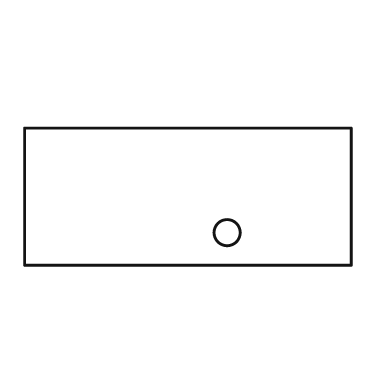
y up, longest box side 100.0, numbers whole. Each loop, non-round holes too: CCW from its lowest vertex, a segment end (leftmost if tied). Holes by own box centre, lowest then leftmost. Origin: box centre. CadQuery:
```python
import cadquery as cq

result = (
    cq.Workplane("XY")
    .moveTo(-50.0, -21.0)
    .lineTo(50.0, -21.0)
    .lineTo(50.0, 21.0)
    .lineTo(-50.0, 21.0)
    .close()
    .moveTo(12.0, -11.0)
    .circle(4.0)
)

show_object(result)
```